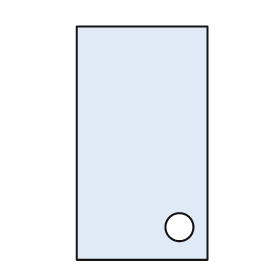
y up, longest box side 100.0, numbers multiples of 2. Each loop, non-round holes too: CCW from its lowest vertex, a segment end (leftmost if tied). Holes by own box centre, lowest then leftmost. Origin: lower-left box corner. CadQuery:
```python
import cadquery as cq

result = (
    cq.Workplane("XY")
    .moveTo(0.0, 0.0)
    .lineTo(56.0, 0.0)
    .lineTo(56.0, 100.0)
    .lineTo(0.0, 100.0)
    .close()
    .moveTo(44.0, 14.0)
    .circle(6.0)
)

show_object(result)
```